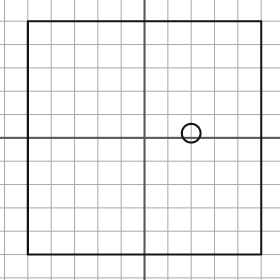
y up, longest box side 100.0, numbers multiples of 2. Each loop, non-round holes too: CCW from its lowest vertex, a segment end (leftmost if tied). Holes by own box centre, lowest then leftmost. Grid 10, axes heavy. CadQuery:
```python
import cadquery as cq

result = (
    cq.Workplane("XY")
    .moveTo(-50.0, -50.0)
    .lineTo(50.0, -50.0)
    .lineTo(50.0, 50.0)
    .lineTo(-50.0, 50.0)
    .close()
    .moveTo(20.0, 2.0)
    .circle(4.0)
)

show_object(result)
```